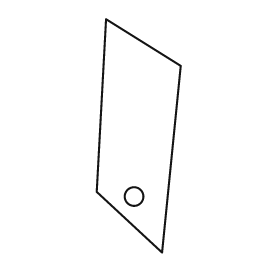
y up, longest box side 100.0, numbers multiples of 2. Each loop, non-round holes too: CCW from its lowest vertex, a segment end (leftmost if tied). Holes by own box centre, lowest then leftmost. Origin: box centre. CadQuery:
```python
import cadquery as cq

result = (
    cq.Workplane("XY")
    .moveTo(10.0, -50.0)
    .lineTo(18.0, 30.0)
    .lineTo(-14.0, 50.0)
    .lineTo(-18.0, -24.0)
    .close()
    .moveTo(-2.0, -26.0)
    .circle(4.0)
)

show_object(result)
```